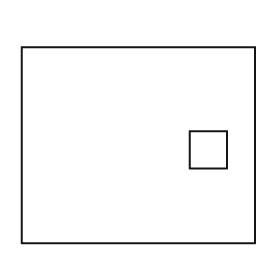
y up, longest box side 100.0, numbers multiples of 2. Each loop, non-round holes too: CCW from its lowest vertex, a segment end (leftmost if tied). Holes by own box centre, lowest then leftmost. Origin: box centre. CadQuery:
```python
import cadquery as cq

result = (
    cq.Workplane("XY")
    .moveTo(-50.0, -42.0)
    .lineTo(50.0, -42.0)
    .lineTo(50.0, 42.0)
    .lineTo(-50.0, 42.0)
    .close()
    .moveTo(22.0, -10.0)
    .lineTo(38.0, -10.0)
    .lineTo(38.0, 6.0)
    .lineTo(22.0, 6.0)
    .close()
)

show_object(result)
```